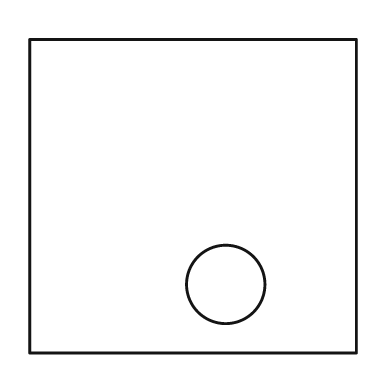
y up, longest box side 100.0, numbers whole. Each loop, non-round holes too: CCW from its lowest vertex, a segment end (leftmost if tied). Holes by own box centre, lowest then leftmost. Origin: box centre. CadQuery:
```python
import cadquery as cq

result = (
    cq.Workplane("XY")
    .moveTo(-50.0, -48.0)
    .lineTo(50.0, -48.0)
    .lineTo(50.0, 48.0)
    .lineTo(-50.0, 48.0)
    .close()
    .moveTo(10.0, -27.0)
    .circle(12.0)
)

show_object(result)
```